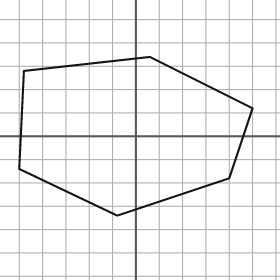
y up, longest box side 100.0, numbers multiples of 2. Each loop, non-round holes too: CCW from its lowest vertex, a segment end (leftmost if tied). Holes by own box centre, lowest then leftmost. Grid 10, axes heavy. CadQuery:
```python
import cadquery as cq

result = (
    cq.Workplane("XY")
    .moveTo(-8.0, -34.0)
    .lineTo(40.0, -18.0)
    .lineTo(50.0, 12.0)
    .lineTo(6.0, 34.0)
    .lineTo(-48.0, 28.0)
    .lineTo(-50.0, -14.0)
    .close()
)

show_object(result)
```